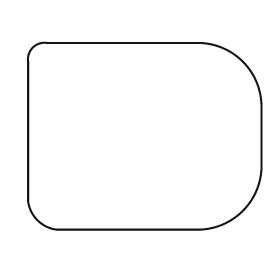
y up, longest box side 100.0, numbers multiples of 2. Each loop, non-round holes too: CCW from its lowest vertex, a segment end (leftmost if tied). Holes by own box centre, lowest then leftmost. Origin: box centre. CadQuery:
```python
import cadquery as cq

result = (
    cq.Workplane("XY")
    .moveTo(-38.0, -40.0)
    .lineTo(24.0, -40.0)
    .threePointArc((42.0, -32.0), (50.0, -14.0))
    .lineTo(50.0, 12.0)
    .threePointArc((42.0, 32.0), (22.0, 40.0))
    .lineTo(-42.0, 40.0)
    .threePointArc((-48.0, 38.0), (-50.0, 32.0))
    .lineTo(-50.0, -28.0)
    .threePointArc((-46.0, -36.0), (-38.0, -40.0))
    .close()
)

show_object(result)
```